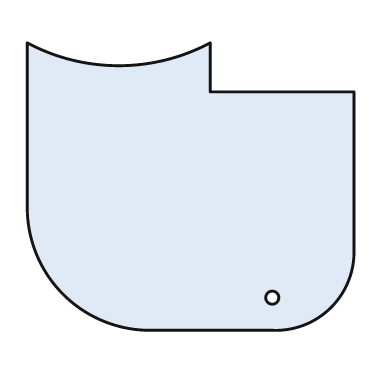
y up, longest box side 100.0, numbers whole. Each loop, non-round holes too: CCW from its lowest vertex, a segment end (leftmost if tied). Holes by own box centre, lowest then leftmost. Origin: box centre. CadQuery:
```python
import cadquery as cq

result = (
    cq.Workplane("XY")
    .moveTo(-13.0, -44.0)
    .lineTo(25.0, -44.0)
    .threePointArc((43.0, -37.0), (50.0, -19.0))
    .lineTo(50.0, 29.0)
    .lineTo(6.0, 29.0)
    .lineTo(6.0, 44.0)
    .threePointArc((-22.0, 37.0), (-50.0, 44.0))
    .lineTo(-50.0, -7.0)
    .threePointArc((-39.0, -33.0), (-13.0, -44.0))
    .close()
    .moveTo(25.0, -34.0)
    .circle(2.0)
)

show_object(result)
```